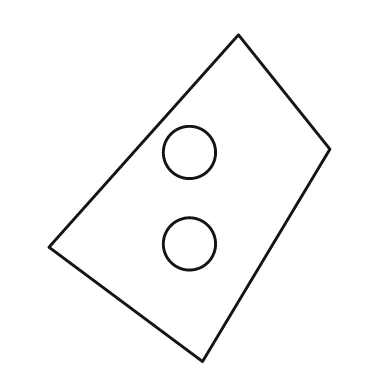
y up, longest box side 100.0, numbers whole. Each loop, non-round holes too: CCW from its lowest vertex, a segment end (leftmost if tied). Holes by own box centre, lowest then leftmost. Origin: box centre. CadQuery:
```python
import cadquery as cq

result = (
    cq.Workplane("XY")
    .moveTo(4.0, -50.0)
    .lineTo(43.0, 15.0)
    .lineTo(15.0, 50.0)
    .lineTo(-43.0, -15.0)
    .close()
    .moveTo(0.0, -14.0)
    .circle(8.0)
    .moveTo(0.0, 14.0)
    .circle(8.0)
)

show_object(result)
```